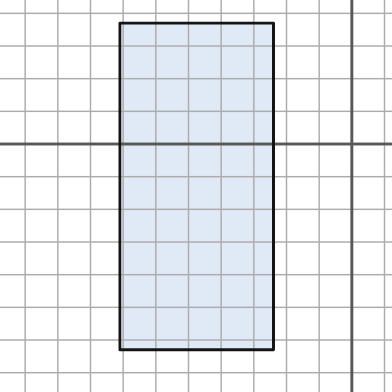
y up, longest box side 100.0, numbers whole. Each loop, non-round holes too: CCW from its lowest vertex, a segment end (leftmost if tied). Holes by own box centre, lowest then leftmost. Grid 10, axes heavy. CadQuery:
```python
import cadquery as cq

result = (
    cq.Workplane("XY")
    .moveTo(-71.0, -63.0)
    .lineTo(-24.0, -63.0)
    .lineTo(-24.0, 37.0)
    .lineTo(-71.0, 37.0)
    .close()
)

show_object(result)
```